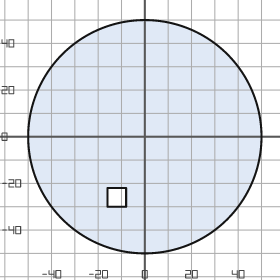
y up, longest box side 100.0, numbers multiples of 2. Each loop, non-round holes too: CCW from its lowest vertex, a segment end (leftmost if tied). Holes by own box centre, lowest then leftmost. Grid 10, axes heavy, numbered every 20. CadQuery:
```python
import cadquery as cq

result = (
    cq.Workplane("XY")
    .moveTo(0.0, 0.0)
    .circle(50.0)
    .moveTo(-16.0, -30.0)
    .lineTo(-8.0, -30.0)
    .lineTo(-8.0, -22.0)
    .lineTo(-16.0, -22.0)
    .close()
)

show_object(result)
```